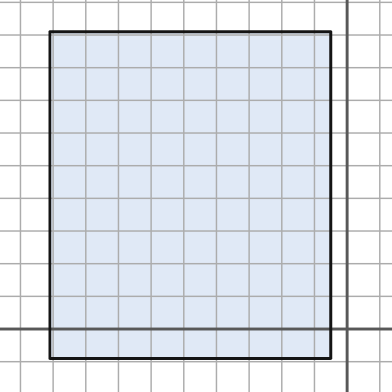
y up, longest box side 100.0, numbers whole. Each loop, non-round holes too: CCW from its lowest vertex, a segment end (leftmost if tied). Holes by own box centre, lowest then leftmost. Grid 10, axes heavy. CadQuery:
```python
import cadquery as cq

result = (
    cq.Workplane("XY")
    .moveTo(-91.0, -9.0)
    .lineTo(-5.0, -9.0)
    .lineTo(-5.0, 91.0)
    .lineTo(-91.0, 91.0)
    .close()
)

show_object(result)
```